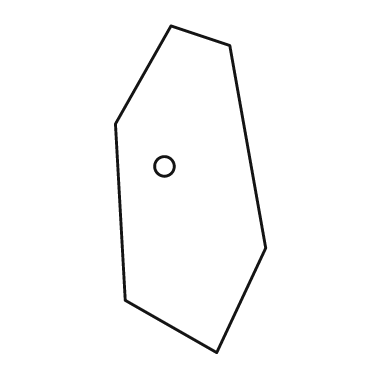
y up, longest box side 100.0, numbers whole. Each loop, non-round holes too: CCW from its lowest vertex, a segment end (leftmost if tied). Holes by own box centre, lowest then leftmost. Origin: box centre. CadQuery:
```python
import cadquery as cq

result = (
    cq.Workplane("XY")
    .moveTo(8.0, -50.0)
    .lineTo(23.0, -18.0)
    .lineTo(12.0, 44.0)
    .lineTo(-6.0, 50.0)
    .lineTo(-23.0, 20.0)
    .lineTo(-20.0, -34.0)
    .close()
    .moveTo(-8.0, 7.0)
    .circle(3.0)
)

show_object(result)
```